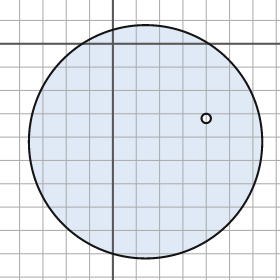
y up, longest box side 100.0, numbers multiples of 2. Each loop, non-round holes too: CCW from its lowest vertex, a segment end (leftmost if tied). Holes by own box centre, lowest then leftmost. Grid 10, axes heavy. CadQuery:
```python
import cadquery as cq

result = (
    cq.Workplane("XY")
    .moveTo(14.0, -42.0)
    .circle(50.0)
    .moveTo(40.0, -32.0)
    .circle(2.0)
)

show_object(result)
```